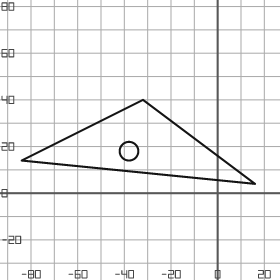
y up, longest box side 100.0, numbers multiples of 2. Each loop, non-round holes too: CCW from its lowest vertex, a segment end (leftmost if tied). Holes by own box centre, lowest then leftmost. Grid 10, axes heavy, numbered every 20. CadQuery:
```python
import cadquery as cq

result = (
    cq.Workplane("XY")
    .moveTo(16.0, 4.0)
    .lineTo(-32.0, 40.0)
    .lineTo(-84.0, 14.0)
    .close()
    .moveTo(-38.0, 18.0)
    .circle(4.0)
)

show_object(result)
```